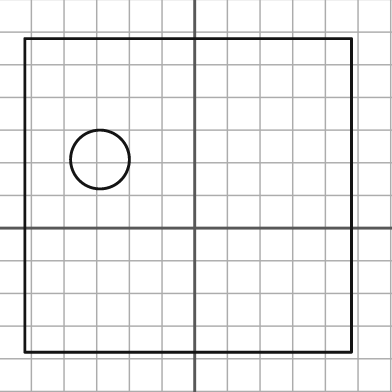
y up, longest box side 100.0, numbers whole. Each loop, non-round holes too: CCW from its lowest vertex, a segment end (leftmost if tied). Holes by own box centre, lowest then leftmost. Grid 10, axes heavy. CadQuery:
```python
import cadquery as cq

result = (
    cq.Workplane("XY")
    .moveTo(-52.0, -38.0)
    .lineTo(48.0, -38.0)
    .lineTo(48.0, 58.0)
    .lineTo(-52.0, 58.0)
    .close()
    .moveTo(-29.0, 21.0)
    .circle(9.0)
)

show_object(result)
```